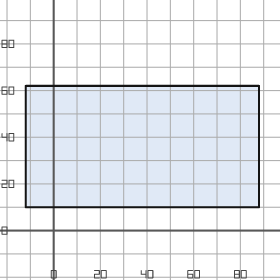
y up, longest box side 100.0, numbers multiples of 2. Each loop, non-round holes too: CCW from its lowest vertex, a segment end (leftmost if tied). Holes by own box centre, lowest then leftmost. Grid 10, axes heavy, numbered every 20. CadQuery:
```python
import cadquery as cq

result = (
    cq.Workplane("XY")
    .moveTo(-12.0, 10.0)
    .lineTo(88.0, 10.0)
    .lineTo(88.0, 62.0)
    .lineTo(-12.0, 62.0)
    .close()
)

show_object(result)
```